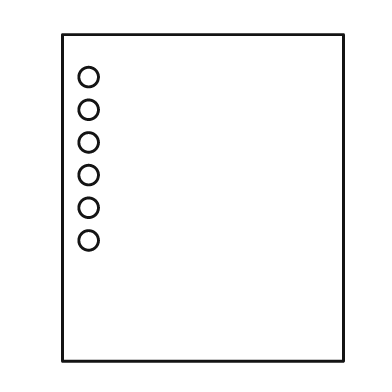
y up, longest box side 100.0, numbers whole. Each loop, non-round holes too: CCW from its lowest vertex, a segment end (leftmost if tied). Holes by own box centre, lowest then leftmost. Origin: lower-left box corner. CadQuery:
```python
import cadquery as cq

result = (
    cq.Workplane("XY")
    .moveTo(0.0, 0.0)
    .lineTo(86.0, 0.0)
    .lineTo(86.0, 100.0)
    .lineTo(0.0, 100.0)
    .close()
    .moveTo(8.0, 37.0)
    .circle(3.0)
    .moveTo(8.0, 47.0)
    .circle(3.0)
    .moveTo(8.0, 57.0)
    .circle(3.0)
    .moveTo(8.0, 67.0)
    .circle(3.0)
    .moveTo(8.0, 77.0)
    .circle(3.0)
    .moveTo(8.0, 87.0)
    .circle(3.0)
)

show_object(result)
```